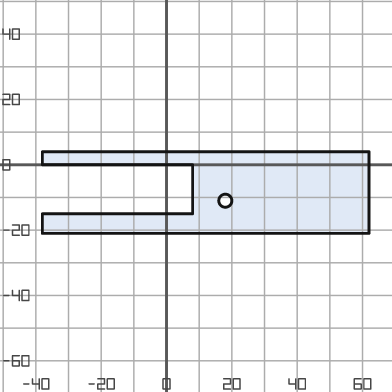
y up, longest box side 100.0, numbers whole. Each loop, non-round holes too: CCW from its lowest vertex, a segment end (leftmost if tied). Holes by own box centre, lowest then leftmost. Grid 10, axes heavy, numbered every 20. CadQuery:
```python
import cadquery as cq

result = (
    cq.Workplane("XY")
    .moveTo(-38.0, -21.0)
    .lineTo(62.0, -21.0)
    .lineTo(62.0, 4.0)
    .lineTo(-38.0, 4.0)
    .lineTo(-38.0, 0.0)
    .lineTo(8.0, 0.0)
    .lineTo(8.0, -15.0)
    .lineTo(-38.0, -15.0)
    .close()
    .moveTo(18.0, -11.0)
    .circle(2.0)
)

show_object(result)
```